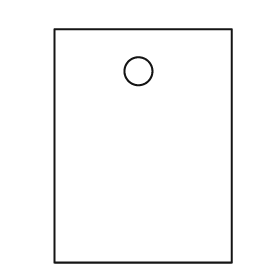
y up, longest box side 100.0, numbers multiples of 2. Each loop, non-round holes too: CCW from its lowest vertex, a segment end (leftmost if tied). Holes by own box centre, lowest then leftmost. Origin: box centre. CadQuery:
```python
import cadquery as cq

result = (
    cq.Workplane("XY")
    .moveTo(-38.0, -50.0)
    .lineTo(38.0, -50.0)
    .lineTo(38.0, 50.0)
    .lineTo(-38.0, 50.0)
    .close()
    .moveTo(-2.0, 32.0)
    .circle(6.0)
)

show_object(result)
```